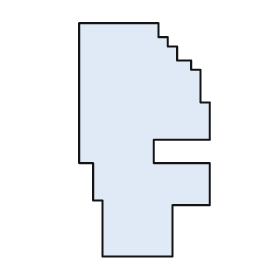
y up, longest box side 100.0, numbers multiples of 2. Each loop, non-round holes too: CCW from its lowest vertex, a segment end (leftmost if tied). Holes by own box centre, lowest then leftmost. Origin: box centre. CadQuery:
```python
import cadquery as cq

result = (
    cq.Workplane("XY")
    .moveTo(-18.0, -50.0)
    .lineTo(12.0, -50.0)
    .lineTo(12.0, -28.0)
    .lineTo(28.0, -28.0)
    .lineTo(28.0, -10.0)
    .lineTo(4.0, -10.0)
    .lineTo(4.0, 0.0)
    .lineTo(28.0, 0.0)
    .lineTo(28.0, 16.0)
    .lineTo(24.0, 16.0)
    .lineTo(24.0, 30.0)
    .lineTo(20.0, 30.0)
    .lineTo(20.0, 34.0)
    .lineTo(14.0, 34.0)
    .lineTo(14.0, 40.0)
    .lineTo(10.0, 40.0)
    .lineTo(10.0, 44.0)
    .lineTo(6.0, 44.0)
    .lineTo(6.0, 50.0)
    .lineTo(-28.0, 50.0)
    .lineTo(-28.0, -10.0)
    .lineTo(-22.0, -10.0)
    .lineTo(-22.0, -26.0)
    .lineTo(-18.0, -26.0)
    .close()
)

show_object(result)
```